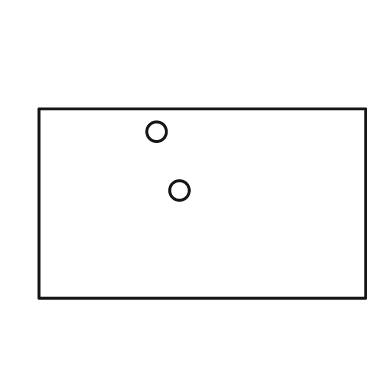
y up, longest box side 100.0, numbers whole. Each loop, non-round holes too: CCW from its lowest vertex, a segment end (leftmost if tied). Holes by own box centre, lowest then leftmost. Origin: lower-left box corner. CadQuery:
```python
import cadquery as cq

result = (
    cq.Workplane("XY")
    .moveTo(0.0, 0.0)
    .lineTo(100.0, 0.0)
    .lineTo(100.0, 58.0)
    .lineTo(0.0, 58.0)
    .close()
    .moveTo(43.0, 33.0)
    .circle(3.0)
    .moveTo(36.0, 51.0)
    .circle(3.0)
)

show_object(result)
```